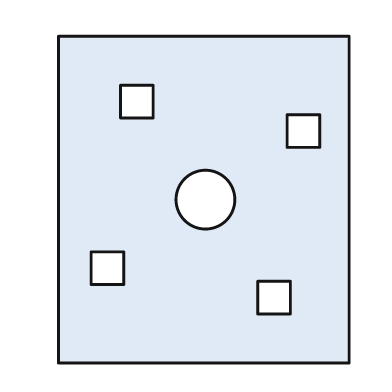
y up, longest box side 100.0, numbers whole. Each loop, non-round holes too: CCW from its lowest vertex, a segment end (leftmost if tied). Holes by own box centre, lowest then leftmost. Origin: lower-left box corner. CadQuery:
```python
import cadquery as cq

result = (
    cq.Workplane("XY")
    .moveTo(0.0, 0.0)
    .lineTo(89.0, 0.0)
    .lineTo(89.0, 100.0)
    .lineTo(0.0, 100.0)
    .close()
    .moveTo(61.0, 15.0)
    .lineTo(71.0, 15.0)
    .lineTo(71.0, 25.0)
    .lineTo(61.0, 25.0)
    .close()
    .moveTo(10.0, 24.0)
    .lineTo(20.0, 24.0)
    .lineTo(20.0, 34.0)
    .lineTo(10.0, 34.0)
    .close()
    .moveTo(45.0, 50.0)
    .circle(9.0)
    .moveTo(70.0, 66.0)
    .lineTo(80.0, 66.0)
    .lineTo(80.0, 76.0)
    .lineTo(70.0, 76.0)
    .close()
    .moveTo(19.0, 75.0)
    .lineTo(29.0, 75.0)
    .lineTo(29.0, 85.0)
    .lineTo(19.0, 85.0)
    .close()
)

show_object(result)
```